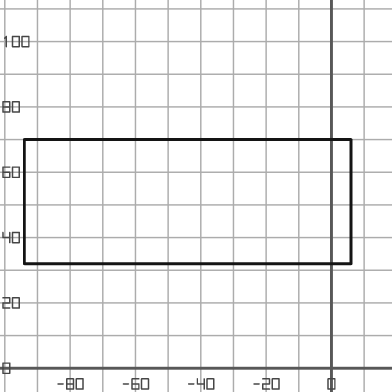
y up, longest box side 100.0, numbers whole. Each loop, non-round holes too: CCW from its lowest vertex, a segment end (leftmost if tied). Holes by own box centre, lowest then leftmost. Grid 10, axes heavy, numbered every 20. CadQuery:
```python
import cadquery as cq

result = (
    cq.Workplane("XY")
    .moveTo(-94.0, 32.0)
    .lineTo(6.0, 32.0)
    .lineTo(6.0, 70.0)
    .lineTo(-94.0, 70.0)
    .close()
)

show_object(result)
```